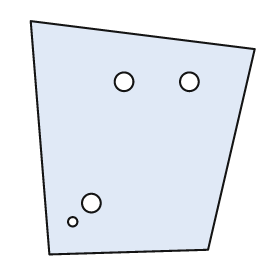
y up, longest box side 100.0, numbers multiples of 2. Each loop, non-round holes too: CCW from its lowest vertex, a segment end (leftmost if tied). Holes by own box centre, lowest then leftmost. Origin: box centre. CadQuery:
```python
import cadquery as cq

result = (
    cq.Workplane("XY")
    .moveTo(-40.0, -50.0)
    .lineTo(28.0, -48.0)
    .lineTo(48.0, 38.0)
    .lineTo(-48.0, 50.0)
    .close()
    .moveTo(-30.0, -36.0)
    .circle(2.0)
    .moveTo(-22.0, -28.0)
    .circle(4.0)
    .moveTo(-8.0, 24.0)
    .circle(4.0)
    .moveTo(20.0, 24.0)
    .circle(4.0)
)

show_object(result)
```